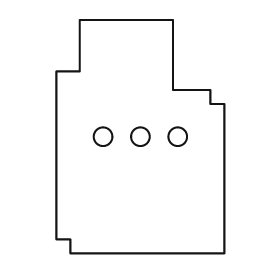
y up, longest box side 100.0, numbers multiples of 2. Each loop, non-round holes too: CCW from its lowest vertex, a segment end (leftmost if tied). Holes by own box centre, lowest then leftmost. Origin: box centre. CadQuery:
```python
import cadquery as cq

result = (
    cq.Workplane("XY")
    .moveTo(-30.0, -50.0)
    .lineTo(36.0, -50.0)
    .lineTo(36.0, 14.0)
    .lineTo(30.0, 14.0)
    .lineTo(30.0, 20.0)
    .lineTo(14.0, 20.0)
    .lineTo(14.0, 50.0)
    .lineTo(-26.0, 50.0)
    .lineTo(-26.0, 28.0)
    .lineTo(-36.0, 28.0)
    .lineTo(-36.0, -44.0)
    .lineTo(-30.0, -44.0)
    .close()
    .moveTo(-16.0, 0.0)
    .circle(4.0)
    .moveTo(0.0, 0.0)
    .circle(4.0)
    .moveTo(16.0, 0.0)
    .circle(4.0)
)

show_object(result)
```